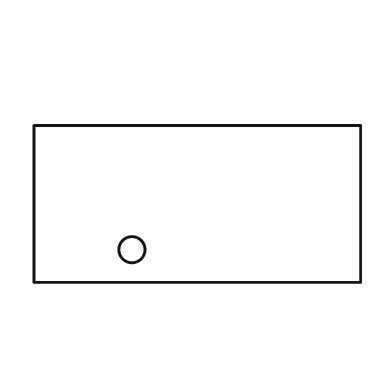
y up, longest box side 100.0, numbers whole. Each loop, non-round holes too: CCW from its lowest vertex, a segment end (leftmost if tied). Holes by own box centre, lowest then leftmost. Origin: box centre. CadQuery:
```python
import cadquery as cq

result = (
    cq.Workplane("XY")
    .moveTo(-50.0, -24.0)
    .lineTo(50.0, -24.0)
    .lineTo(50.0, 24.0)
    .lineTo(-50.0, 24.0)
    .close()
    .moveTo(-20.0, -14.0)
    .circle(4.0)
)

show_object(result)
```